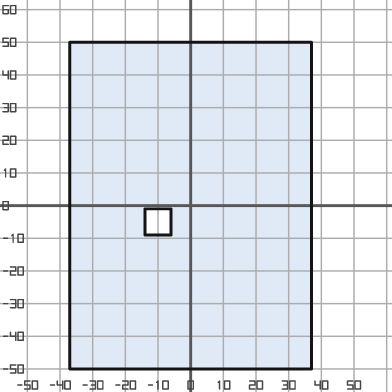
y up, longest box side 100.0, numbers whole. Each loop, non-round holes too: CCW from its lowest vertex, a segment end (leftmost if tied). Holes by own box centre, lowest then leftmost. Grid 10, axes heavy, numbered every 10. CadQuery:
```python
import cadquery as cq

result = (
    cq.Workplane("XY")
    .moveTo(-37.0, -50.0)
    .lineTo(37.0, -50.0)
    .lineTo(37.0, 50.0)
    .lineTo(-37.0, 50.0)
    .close()
    .moveTo(-14.0, -9.0)
    .lineTo(-6.0, -9.0)
    .lineTo(-6.0, -1.0)
    .lineTo(-14.0, -1.0)
    .close()
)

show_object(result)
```